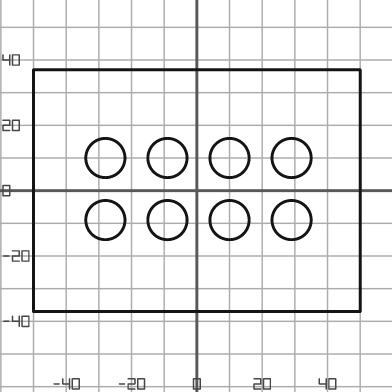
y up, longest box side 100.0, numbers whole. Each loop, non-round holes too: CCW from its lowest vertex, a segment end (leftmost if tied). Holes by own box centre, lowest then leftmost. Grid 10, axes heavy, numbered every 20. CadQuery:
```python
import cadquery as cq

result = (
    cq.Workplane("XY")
    .moveTo(-50.0, -37.0)
    .lineTo(50.0, -37.0)
    .lineTo(50.0, 37.0)
    .lineTo(-50.0, 37.0)
    .close()
    .moveTo(-28.0, -9.0)
    .circle(6.0)
    .moveTo(-9.0, -9.0)
    .circle(6.0)
    .moveTo(10.0, -9.0)
    .circle(6.0)
    .moveTo(29.0, -9.0)
    .circle(6.0)
    .moveTo(-28.0, 10.0)
    .circle(6.0)
    .moveTo(-9.0, 10.0)
    .circle(6.0)
    .moveTo(10.0, 10.0)
    .circle(6.0)
    .moveTo(29.0, 10.0)
    .circle(6.0)
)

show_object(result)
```